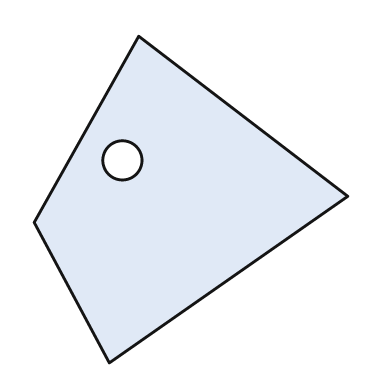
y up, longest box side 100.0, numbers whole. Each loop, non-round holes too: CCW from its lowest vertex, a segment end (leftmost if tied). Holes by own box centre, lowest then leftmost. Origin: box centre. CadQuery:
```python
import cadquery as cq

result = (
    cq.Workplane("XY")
    .moveTo(-25.0, -50.0)
    .lineTo(48.0, 1.0)
    .lineTo(-16.0, 50.0)
    .lineTo(-48.0, -7.0)
    .close()
    .moveTo(-21.0, 12.0)
    .circle(6.0)
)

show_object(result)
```